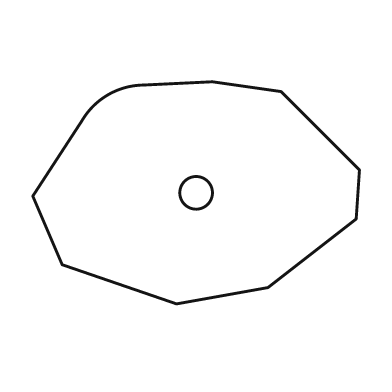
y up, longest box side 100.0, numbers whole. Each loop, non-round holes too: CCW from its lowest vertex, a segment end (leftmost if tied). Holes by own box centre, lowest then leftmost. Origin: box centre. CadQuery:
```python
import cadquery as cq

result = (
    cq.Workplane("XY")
    .moveTo(-6.0, -34.0)
    .lineTo(22.0, -29.0)
    .lineTo(49.0, -8.0)
    .lineTo(50.0, 7.0)
    .lineTo(26.0, 31.0)
    .lineTo(5.0, 34.0)
    .lineTo(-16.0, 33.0)
    .threePointArc((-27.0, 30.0), (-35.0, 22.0))
    .lineTo(-50.0, -1.0)
    .lineTo(-41.0, -22.0)
    .close()
    .moveTo(0.0, 0.0)
    .circle(5.0)
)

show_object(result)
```